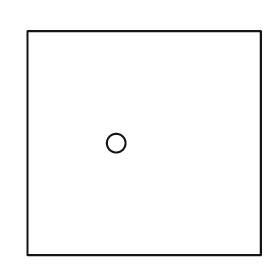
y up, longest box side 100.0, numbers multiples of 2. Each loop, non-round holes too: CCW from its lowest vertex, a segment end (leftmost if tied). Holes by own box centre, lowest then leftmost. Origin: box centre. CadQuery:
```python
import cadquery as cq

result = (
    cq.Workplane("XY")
    .moveTo(-50.0, -48.0)
    .lineTo(50.0, -48.0)
    .lineTo(50.0, 48.0)
    .lineTo(-50.0, 48.0)
    .close()
    .moveTo(-12.0, 0.0)
    .circle(4.0)
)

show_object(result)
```